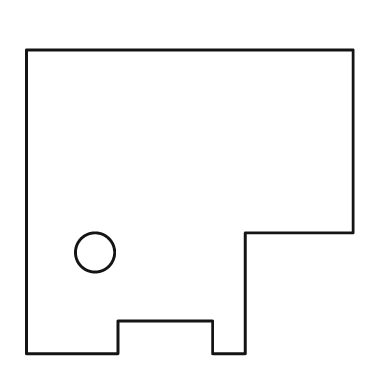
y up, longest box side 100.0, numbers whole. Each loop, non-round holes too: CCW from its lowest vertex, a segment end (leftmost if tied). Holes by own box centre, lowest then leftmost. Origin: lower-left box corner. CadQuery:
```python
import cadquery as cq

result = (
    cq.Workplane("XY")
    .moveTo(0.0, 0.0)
    .lineTo(28.0, 0.0)
    .lineTo(28.0, 10.0)
    .lineTo(57.0, 10.0)
    .lineTo(57.0, 0.0)
    .lineTo(67.0, 0.0)
    .lineTo(67.0, 37.0)
    .lineTo(100.0, 37.0)
    .lineTo(100.0, 93.0)
    .lineTo(0.0, 93.0)
    .close()
    .moveTo(21.0, 31.0)
    .circle(6.0)
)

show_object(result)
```